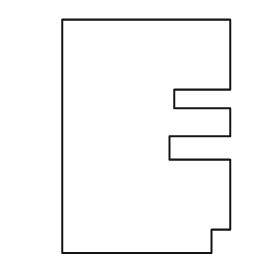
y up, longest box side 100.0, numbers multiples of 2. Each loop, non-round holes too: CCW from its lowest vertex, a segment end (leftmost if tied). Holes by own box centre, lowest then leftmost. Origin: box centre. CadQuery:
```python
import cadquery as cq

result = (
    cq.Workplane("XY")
    .moveTo(-36.0, -50.0)
    .lineTo(28.0, -50.0)
    .lineTo(28.0, -40.0)
    .lineTo(36.0, -40.0)
    .lineTo(36.0, -10.0)
    .lineTo(10.0, -10.0)
    .lineTo(10.0, 0.0)
    .lineTo(36.0, 0.0)
    .lineTo(36.0, 12.0)
    .lineTo(12.0, 12.0)
    .lineTo(12.0, 20.0)
    .lineTo(36.0, 20.0)
    .lineTo(36.0, 50.0)
    .lineTo(-36.0, 50.0)
    .close()
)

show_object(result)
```